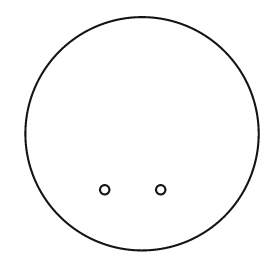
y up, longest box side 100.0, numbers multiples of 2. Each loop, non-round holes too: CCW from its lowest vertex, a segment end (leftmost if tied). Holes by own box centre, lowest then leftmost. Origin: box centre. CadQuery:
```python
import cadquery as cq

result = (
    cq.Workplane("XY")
    .moveTo(0.0, 0.0)
    .circle(50.0)
    .moveTo(-16.0, -24.0)
    .circle(2.0)
    .moveTo(8.0, -24.0)
    .circle(2.0)
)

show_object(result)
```